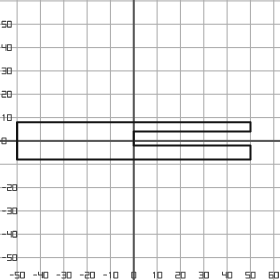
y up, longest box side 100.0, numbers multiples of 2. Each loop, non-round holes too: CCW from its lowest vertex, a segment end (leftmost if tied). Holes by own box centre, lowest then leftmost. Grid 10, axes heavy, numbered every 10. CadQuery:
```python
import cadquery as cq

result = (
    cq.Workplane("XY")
    .moveTo(-50.0, -8.0)
    .lineTo(50.0, -8.0)
    .lineTo(50.0, -2.0)
    .lineTo(0.0, -2.0)
    .lineTo(0.0, 4.0)
    .lineTo(50.0, 4.0)
    .lineTo(50.0, 8.0)
    .lineTo(-50.0, 8.0)
    .close()
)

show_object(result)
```